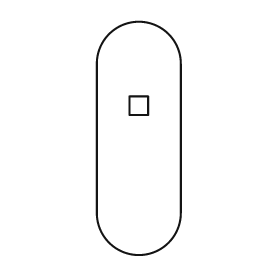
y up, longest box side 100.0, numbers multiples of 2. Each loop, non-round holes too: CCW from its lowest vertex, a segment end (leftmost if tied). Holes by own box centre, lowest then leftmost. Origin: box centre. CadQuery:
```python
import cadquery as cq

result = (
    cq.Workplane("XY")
    .moveTo(-18.0, -32.0)
    .threePointArc((0.0, -50.0), (18.0, -32.0))
    .lineTo(18.0, 32.0)
    .threePointArc((0.0, 50.0), (-18.0, 32.0))
    .close()
    .moveTo(-4.0, 10.0)
    .lineTo(4.0, 10.0)
    .lineTo(4.0, 18.0)
    .lineTo(-4.0, 18.0)
    .close()
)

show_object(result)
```